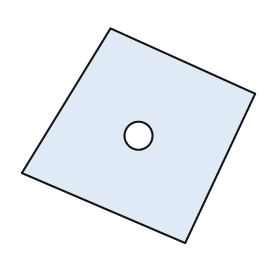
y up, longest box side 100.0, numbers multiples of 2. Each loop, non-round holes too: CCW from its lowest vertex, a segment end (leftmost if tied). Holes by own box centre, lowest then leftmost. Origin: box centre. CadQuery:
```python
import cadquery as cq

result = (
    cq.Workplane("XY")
    .moveTo(20.0, -46.0)
    .lineTo(50.0, 18.0)
    .lineTo(-12.0, 46.0)
    .lineTo(-50.0, -16.0)
    .close()
    .moveTo(0.0, 0.0)
    .circle(6.0)
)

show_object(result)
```